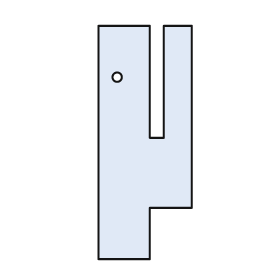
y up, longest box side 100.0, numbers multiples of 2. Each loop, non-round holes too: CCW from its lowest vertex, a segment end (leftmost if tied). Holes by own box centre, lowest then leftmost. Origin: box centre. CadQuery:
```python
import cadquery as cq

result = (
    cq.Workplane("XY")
    .moveTo(-20.0, -50.0)
    .lineTo(2.0, -50.0)
    .lineTo(2.0, -28.0)
    .lineTo(20.0, -28.0)
    .lineTo(20.0, 50.0)
    .lineTo(8.0, 50.0)
    .lineTo(8.0, 2.0)
    .lineTo(2.0, 2.0)
    .lineTo(2.0, 50.0)
    .lineTo(-20.0, 50.0)
    .close()
    .moveTo(-12.0, 28.0)
    .circle(2.0)
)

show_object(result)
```